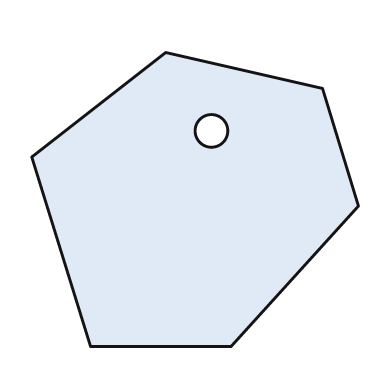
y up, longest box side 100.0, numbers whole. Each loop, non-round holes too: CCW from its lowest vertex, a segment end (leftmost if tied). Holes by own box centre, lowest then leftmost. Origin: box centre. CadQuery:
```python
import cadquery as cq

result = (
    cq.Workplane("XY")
    .moveTo(-32.0, -45.0)
    .lineTo(11.0, -45.0)
    .lineTo(50.0, -2.0)
    .lineTo(39.0, 34.0)
    .lineTo(-9.0, 45.0)
    .lineTo(-50.0, 13.0)
    .close()
    .moveTo(5.0, 21.0)
    .circle(5.0)
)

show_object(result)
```